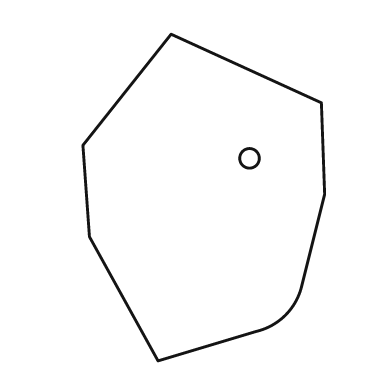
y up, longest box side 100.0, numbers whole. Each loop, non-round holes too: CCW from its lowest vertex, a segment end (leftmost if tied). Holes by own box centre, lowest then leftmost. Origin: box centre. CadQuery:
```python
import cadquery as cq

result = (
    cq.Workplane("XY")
    .moveTo(-14.0, -50.0)
    .lineTo(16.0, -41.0)
    .threePointArc((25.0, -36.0), (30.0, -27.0))
    .lineTo(37.0, 1.0)
    .lineTo(36.0, 29.0)
    .lineTo(-10.0, 50.0)
    .lineTo(-37.0, 16.0)
    .lineTo(-35.0, -12.0)
    .close()
    .moveTo(14.0, 12.0)
    .circle(3.0)
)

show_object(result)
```